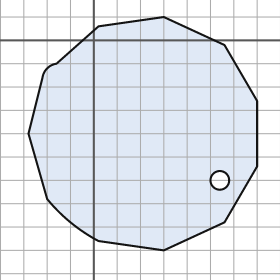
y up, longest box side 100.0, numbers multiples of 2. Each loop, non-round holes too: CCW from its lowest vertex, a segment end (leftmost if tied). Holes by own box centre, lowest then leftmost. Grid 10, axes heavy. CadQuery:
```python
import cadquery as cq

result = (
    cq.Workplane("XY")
    .moveTo(30.0, -90.0)
    .lineTo(56.0, -78.0)
    .lineTo(70.0, -54.0)
    .lineTo(70.0, -26.0)
    .lineTo(56.0, -2.0)
    .lineTo(30.0, 10.0)
    .lineTo(2.0, 6.0)
    .lineTo(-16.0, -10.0)
    .threePointArc((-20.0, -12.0), (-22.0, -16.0))
    .lineTo(-28.0, -40.0)
    .lineTo(-20.0, -68.0)
    .threePointArc((-10.0, -78.0), (2.0, -86.0))
    .close()
    .moveTo(54.0, -60.0)
    .circle(4.0)
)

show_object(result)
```